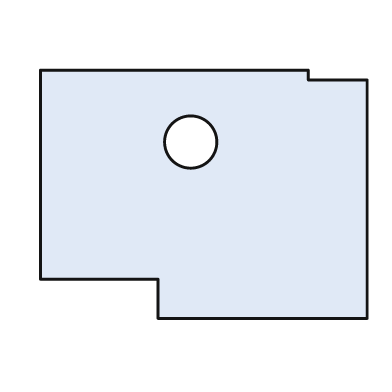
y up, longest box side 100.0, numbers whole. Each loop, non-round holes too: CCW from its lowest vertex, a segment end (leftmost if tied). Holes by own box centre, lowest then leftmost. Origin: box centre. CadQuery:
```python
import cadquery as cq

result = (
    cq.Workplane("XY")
    .moveTo(-14.0, -38.0)
    .lineTo(50.0, -38.0)
    .lineTo(50.0, 35.0)
    .lineTo(32.0, 35.0)
    .lineTo(32.0, 38.0)
    .lineTo(-50.0, 38.0)
    .lineTo(-50.0, -26.0)
    .lineTo(-14.0, -26.0)
    .close()
    .moveTo(-4.0, 16.0)
    .circle(8.0)
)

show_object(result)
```